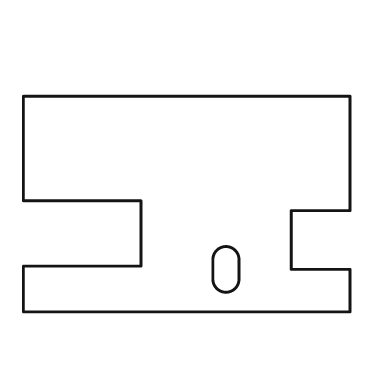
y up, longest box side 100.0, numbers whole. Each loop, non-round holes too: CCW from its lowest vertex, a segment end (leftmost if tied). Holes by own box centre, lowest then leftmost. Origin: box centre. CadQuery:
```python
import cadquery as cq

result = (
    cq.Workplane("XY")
    .moveTo(-50.0, -33.0)
    .lineTo(50.0, -33.0)
    .lineTo(50.0, -20.0)
    .lineTo(32.0, -20.0)
    .lineTo(32.0, -2.0)
    .lineTo(50.0, -2.0)
    .lineTo(50.0, 33.0)
    .lineTo(-50.0, 33.0)
    .lineTo(-50.0, 1.0)
    .lineTo(-14.0, 1.0)
    .lineTo(-14.0, -19.0)
    .lineTo(-50.0, -19.0)
    .close()
    .moveTo(8.0, -23.0)
    .threePointArc((12.0, -27.0), (16.0, -23.0))
    .lineTo(16.0, -17.0)
    .threePointArc((12.0, -13.0), (8.0, -17.0))
    .close()
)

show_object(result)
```